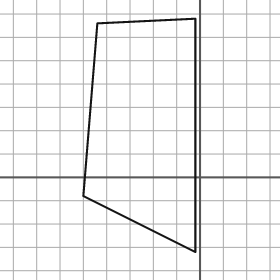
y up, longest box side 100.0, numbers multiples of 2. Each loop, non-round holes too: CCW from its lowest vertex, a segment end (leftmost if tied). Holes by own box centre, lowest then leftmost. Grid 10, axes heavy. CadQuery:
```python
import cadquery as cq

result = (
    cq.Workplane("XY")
    .moveTo(-2.0, -32.0)
    .lineTo(-2.0, 68.0)
    .lineTo(-44.0, 66.0)
    .lineTo(-50.0, -8.0)
    .close()
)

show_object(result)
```